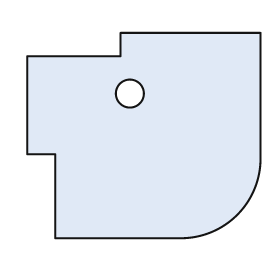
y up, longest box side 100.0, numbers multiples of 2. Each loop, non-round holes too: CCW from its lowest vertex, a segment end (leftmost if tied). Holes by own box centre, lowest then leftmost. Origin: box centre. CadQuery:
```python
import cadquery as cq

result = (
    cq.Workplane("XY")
    .moveTo(-38.0, -44.0)
    .lineTo(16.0, -44.0)
    .threePointArc((40.0, -34.0), (50.0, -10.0))
    .lineTo(50.0, 44.0)
    .lineTo(-10.0, 44.0)
    .lineTo(-10.0, 34.0)
    .lineTo(-50.0, 34.0)
    .lineTo(-50.0, -8.0)
    .lineTo(-38.0, -8.0)
    .close()
    .moveTo(-6.0, 18.0)
    .circle(6.0)
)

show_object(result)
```